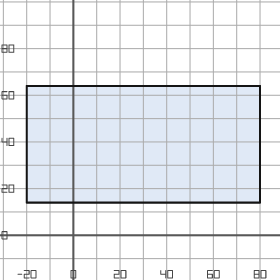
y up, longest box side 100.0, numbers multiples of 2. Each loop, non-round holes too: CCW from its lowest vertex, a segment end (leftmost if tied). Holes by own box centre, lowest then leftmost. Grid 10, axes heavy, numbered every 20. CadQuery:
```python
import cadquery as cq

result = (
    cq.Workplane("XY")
    .moveTo(-20.0, 14.0)
    .lineTo(80.0, 14.0)
    .lineTo(80.0, 64.0)
    .lineTo(-20.0, 64.0)
    .close()
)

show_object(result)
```